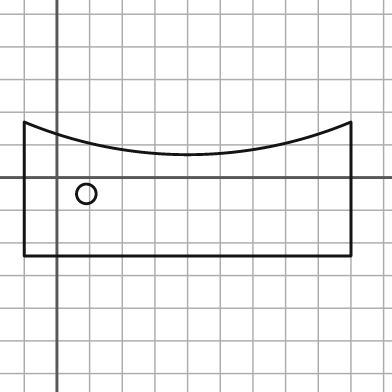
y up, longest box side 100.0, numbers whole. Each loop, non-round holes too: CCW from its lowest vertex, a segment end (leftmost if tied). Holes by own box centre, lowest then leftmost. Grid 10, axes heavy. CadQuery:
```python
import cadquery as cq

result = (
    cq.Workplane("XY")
    .moveTo(-10.0, -24.0)
    .lineTo(90.0, -24.0)
    .lineTo(90.0, 17.0)
    .threePointArc((40.0, 7.0), (-10.0, 17.0))
    .close()
    .moveTo(9.0, -5.0)
    .circle(3.0)
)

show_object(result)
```